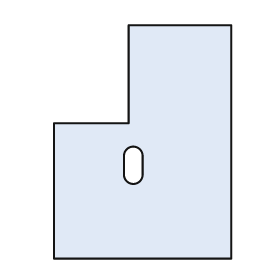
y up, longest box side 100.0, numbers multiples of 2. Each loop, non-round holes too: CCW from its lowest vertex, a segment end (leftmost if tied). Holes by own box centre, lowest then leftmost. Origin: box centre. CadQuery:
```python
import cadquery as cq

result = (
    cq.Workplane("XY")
    .moveTo(-38.0, -50.0)
    .lineTo(38.0, -50.0)
    .lineTo(38.0, 50.0)
    .lineTo(-6.0, 50.0)
    .lineTo(-6.0, 8.0)
    .lineTo(-38.0, 8.0)
    .close()
    .moveTo(-8.0, -14.0)
    .threePointArc((-4.0, -18.0), (0.0, -14.0))
    .lineTo(0.0, -6.0)
    .threePointArc((-4.0, -2.0), (-8.0, -6.0))
    .close()
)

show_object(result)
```